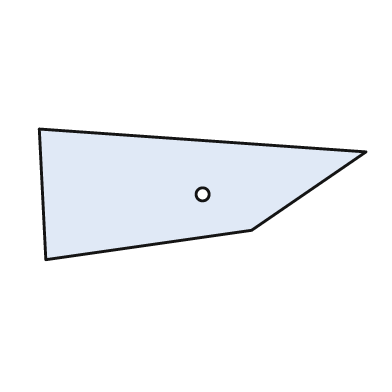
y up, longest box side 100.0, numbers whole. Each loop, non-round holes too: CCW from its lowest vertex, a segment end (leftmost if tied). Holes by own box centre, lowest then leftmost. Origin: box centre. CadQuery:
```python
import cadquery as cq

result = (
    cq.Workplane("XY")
    .moveTo(-48.0, -20.0)
    .lineTo(15.0, -11.0)
    .lineTo(50.0, 13.0)
    .lineTo(-50.0, 20.0)
    .close()
    .moveTo(0.0, 0.0)
    .circle(2.0)
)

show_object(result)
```